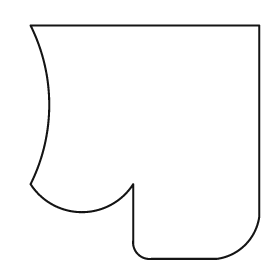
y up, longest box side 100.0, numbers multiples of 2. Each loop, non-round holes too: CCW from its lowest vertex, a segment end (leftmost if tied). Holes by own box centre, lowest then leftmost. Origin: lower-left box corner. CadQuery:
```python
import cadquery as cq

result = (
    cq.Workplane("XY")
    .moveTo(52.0, 0.0)
    .lineTo(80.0, 0.0)
    .threePointArc((92.0, 6.0), (98.0, 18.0))
    .lineTo(98.0, 100.0)
    .lineTo(0.0, 100.0)
    .threePointArc((8.0, 66.0), (0.0, 32.0))
    .threePointArc((22.0, 20.0), (44.0, 32.0))
    .lineTo(44.0, 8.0)
    .threePointArc((46.0, 2.0), (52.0, 0.0))
    .close()
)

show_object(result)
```